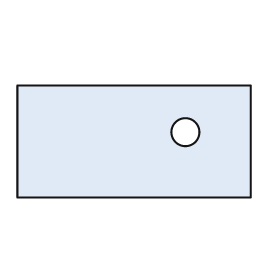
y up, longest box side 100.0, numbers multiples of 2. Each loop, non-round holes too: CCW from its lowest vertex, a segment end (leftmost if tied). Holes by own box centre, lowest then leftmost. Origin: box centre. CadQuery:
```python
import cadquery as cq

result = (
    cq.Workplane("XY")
    .moveTo(-50.0, -24.0)
    .lineTo(50.0, -24.0)
    .lineTo(50.0, 24.0)
    .lineTo(-50.0, 24.0)
    .close()
    .moveTo(22.0, 4.0)
    .circle(6.0)
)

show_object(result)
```